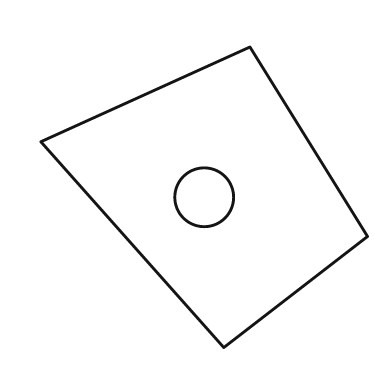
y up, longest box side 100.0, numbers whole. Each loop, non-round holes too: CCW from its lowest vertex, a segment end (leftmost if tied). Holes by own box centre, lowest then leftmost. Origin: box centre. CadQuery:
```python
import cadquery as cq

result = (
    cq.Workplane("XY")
    .moveTo(6.0, -46.0)
    .lineTo(50.0, -12.0)
    .lineTo(14.0, 46.0)
    .lineTo(-50.0, 17.0)
    .close()
    .moveTo(0.0, 0.0)
    .circle(9.0)
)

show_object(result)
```